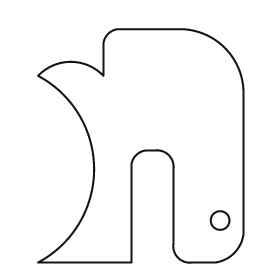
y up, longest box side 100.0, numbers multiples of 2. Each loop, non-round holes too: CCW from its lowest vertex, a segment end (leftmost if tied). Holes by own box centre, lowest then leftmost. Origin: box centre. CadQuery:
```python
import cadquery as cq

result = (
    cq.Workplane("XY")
    .moveTo(-44.0, -50.0)
    .lineTo(-4.0, -50.0)
    .lineTo(-4.0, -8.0)
    .threePointArc((-2.0, -4.0), (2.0, -2.0))
    .lineTo(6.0, -2.0)
    .threePointArc((12.0, -4.0), (14.0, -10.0))
    .lineTo(14.0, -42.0)
    .threePointArc((16.0, -48.0), (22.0, -50.0))
    .lineTo(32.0, -50.0)
    .threePointArc((40.0, -46.0), (44.0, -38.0))
    .lineTo(44.0, 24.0)
    .threePointArc((36.0, 42.0), (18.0, 50.0))
    .lineTo(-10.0, 50.0)
    .threePointArc((-14.0, 48.0), (-16.0, 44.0))
    .lineTo(-16.0, 30.0)
    .threePointArc((-30.0, 36.0), (-44.0, 30.0))
    .threePointArc((-20.0, -10.0), (-44.0, -50.0))
    .close()
    .moveTo(34.0, -32.0)
    .circle(4.0)
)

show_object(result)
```